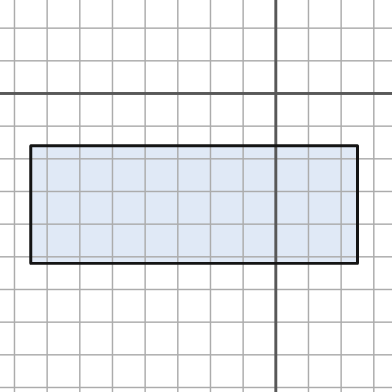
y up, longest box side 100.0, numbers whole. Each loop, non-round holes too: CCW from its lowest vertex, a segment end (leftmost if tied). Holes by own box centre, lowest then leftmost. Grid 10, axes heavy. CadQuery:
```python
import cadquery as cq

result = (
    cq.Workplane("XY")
    .moveTo(-75.0, -52.0)
    .lineTo(25.0, -52.0)
    .lineTo(25.0, -16.0)
    .lineTo(-75.0, -16.0)
    .close()
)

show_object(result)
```